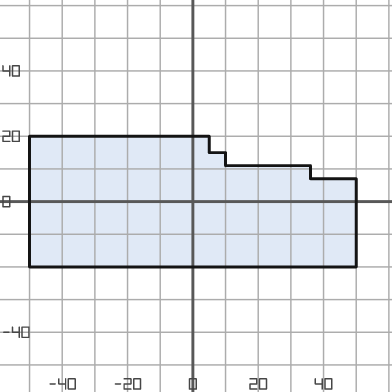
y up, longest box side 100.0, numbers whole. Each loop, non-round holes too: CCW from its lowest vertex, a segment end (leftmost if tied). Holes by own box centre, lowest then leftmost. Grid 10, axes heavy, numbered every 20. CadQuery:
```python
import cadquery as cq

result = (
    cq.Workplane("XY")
    .moveTo(-50.0, -20.0)
    .lineTo(50.0, -20.0)
    .lineTo(50.0, 7.0)
    .lineTo(36.0, 7.0)
    .lineTo(36.0, 11.0)
    .lineTo(10.0, 11.0)
    .lineTo(10.0, 15.0)
    .lineTo(5.0, 15.0)
    .lineTo(5.0, 20.0)
    .lineTo(-50.0, 20.0)
    .close()
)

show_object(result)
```